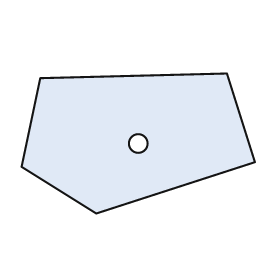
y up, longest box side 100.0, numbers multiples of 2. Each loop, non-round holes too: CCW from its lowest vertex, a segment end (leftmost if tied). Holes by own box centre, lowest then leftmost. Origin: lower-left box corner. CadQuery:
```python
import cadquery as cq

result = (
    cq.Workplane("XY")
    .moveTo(32.0, 0.0)
    .lineTo(100.0, 22.0)
    .lineTo(88.0, 60.0)
    .lineTo(8.0, 58.0)
    .lineTo(0.0, 20.0)
    .close()
    .moveTo(50.0, 30.0)
    .circle(4.0)
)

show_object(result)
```